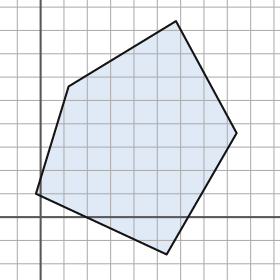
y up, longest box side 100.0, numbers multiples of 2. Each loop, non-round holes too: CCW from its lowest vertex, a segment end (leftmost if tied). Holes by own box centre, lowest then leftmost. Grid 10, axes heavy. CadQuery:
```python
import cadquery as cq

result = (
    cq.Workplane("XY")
    .moveTo(54.0, -16.0)
    .lineTo(84.0, 36.0)
    .lineTo(58.0, 84.0)
    .lineTo(12.0, 56.0)
    .lineTo(-2.0, 10.0)
    .close()
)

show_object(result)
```